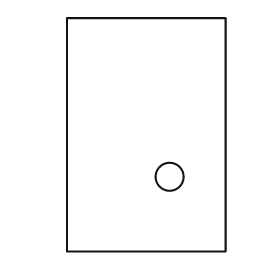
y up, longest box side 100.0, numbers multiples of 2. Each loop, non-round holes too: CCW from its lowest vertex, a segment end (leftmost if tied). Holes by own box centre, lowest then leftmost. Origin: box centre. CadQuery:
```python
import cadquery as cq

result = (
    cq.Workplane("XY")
    .moveTo(-34.0, -50.0)
    .lineTo(34.0, -50.0)
    .lineTo(34.0, 50.0)
    .lineTo(-34.0, 50.0)
    .close()
    .moveTo(10.0, -18.0)
    .circle(6.0)
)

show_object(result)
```